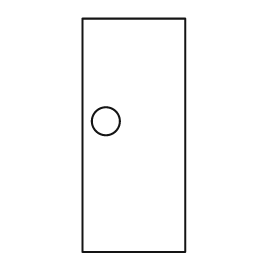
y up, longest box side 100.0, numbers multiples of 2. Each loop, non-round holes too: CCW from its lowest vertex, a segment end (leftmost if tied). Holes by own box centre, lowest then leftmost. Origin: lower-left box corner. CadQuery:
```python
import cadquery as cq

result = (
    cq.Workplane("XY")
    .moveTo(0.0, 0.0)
    .lineTo(44.0, 0.0)
    .lineTo(44.0, 100.0)
    .lineTo(0.0, 100.0)
    .close()
    .moveTo(10.0, 56.0)
    .circle(6.0)
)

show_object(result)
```